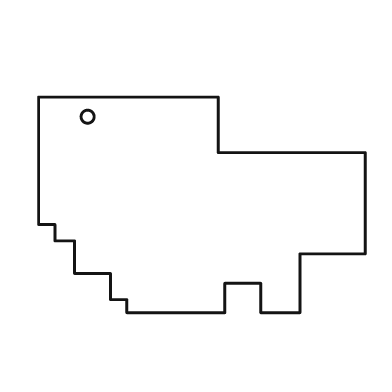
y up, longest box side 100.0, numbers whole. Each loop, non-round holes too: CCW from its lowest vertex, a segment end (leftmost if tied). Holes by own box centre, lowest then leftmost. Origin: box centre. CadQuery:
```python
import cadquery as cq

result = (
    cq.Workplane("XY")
    .moveTo(-23.0, -33.0)
    .lineTo(7.0, -33.0)
    .lineTo(7.0, -24.0)
    .lineTo(18.0, -24.0)
    .lineTo(18.0, -33.0)
    .lineTo(30.0, -33.0)
    .lineTo(30.0, -15.0)
    .lineTo(50.0, -15.0)
    .lineTo(50.0, 16.0)
    .lineTo(5.0, 16.0)
    .lineTo(5.0, 33.0)
    .lineTo(-50.0, 33.0)
    .lineTo(-50.0, -6.0)
    .lineTo(-45.0, -6.0)
    .lineTo(-45.0, -11.0)
    .lineTo(-39.0, -11.0)
    .lineTo(-39.0, -21.0)
    .lineTo(-28.0, -21.0)
    .lineTo(-28.0, -29.0)
    .lineTo(-23.0, -29.0)
    .close()
    .moveTo(-35.0, 27.0)
    .circle(2.0)
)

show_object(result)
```